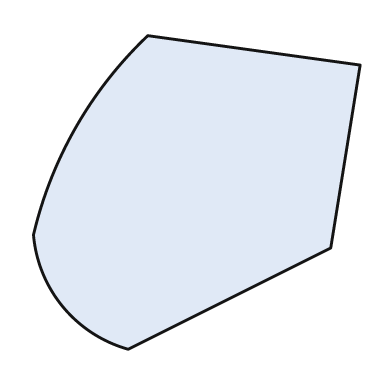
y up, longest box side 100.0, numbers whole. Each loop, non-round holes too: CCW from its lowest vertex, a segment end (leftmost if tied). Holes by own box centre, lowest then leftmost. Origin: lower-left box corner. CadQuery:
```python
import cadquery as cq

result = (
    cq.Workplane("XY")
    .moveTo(29.0, 0.0)
    .lineTo(91.0, 31.0)
    .lineTo(100.0, 87.0)
    .lineTo(35.0, 96.0)
    .threePointArc((13.0, 68.0), (0.0, 35.0))
    .threePointArc((9.0, 13.0), (29.0, 0.0))
    .close()
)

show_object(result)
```